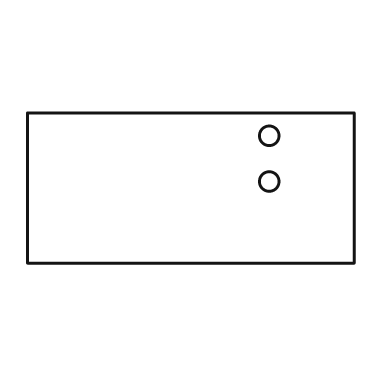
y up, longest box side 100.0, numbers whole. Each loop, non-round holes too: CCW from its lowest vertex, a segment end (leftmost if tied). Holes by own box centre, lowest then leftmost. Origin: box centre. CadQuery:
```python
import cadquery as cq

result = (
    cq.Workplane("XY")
    .moveTo(-50.0, -23.0)
    .lineTo(50.0, -23.0)
    .lineTo(50.0, 23.0)
    .lineTo(-50.0, 23.0)
    .close()
    .moveTo(24.0, 2.0)
    .circle(3.0)
    .moveTo(24.0, 16.0)
    .circle(3.0)
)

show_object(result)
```